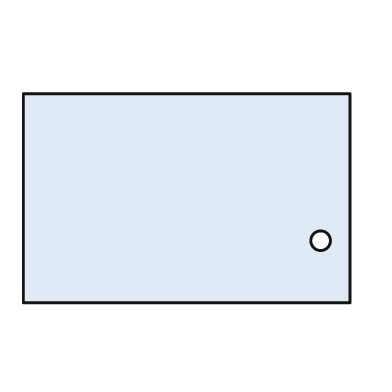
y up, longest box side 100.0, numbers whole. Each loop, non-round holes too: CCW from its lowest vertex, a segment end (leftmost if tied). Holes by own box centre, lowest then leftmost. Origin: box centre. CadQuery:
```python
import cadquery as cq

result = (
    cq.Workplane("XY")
    .moveTo(-50.0, -32.0)
    .lineTo(50.0, -32.0)
    .lineTo(50.0, 32.0)
    .lineTo(-50.0, 32.0)
    .close()
    .moveTo(41.0, -13.0)
    .circle(3.0)
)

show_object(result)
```